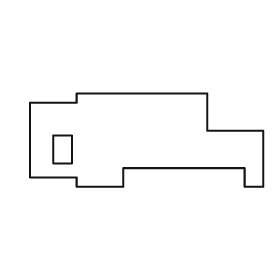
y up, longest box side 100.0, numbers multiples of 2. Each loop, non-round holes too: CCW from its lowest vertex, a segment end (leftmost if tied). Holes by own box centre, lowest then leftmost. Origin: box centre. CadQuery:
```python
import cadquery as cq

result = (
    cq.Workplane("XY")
    .moveTo(-30.0, -20.0)
    .lineTo(-10.0, -20.0)
    .lineTo(-10.0, -12.0)
    .lineTo(42.0, -12.0)
    .lineTo(42.0, -20.0)
    .lineTo(50.0, -20.0)
    .lineTo(50.0, 4.0)
    .lineTo(26.0, 4.0)
    .lineTo(26.0, 20.0)
    .lineTo(-30.0, 20.0)
    .lineTo(-30.0, 16.0)
    .lineTo(-50.0, 16.0)
    .lineTo(-50.0, -16.0)
    .lineTo(-30.0, -16.0)
    .close()
    .moveTo(-40.0, -10.0)
    .lineTo(-32.0, -10.0)
    .lineTo(-32.0, 2.0)
    .lineTo(-40.0, 2.0)
    .close()
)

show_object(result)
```